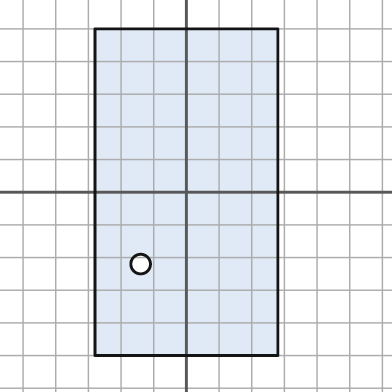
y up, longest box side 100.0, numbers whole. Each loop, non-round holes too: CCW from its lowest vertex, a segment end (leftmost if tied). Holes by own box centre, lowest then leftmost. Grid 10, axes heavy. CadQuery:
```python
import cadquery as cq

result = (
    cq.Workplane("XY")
    .moveTo(-28.0, -50.0)
    .lineTo(28.0, -50.0)
    .lineTo(28.0, 50.0)
    .lineTo(-28.0, 50.0)
    .close()
    .moveTo(-14.0, -22.0)
    .circle(3.0)
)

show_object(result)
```